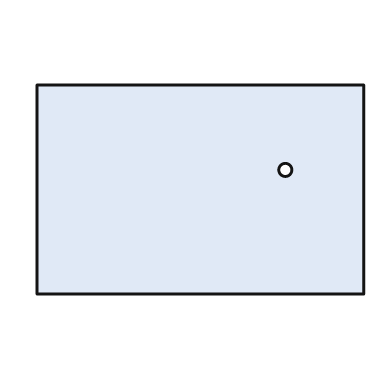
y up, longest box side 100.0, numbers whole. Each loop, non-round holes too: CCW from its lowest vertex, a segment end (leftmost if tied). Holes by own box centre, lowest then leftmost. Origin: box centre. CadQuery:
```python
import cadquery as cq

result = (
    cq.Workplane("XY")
    .moveTo(-50.0, -32.0)
    .lineTo(50.0, -32.0)
    .lineTo(50.0, 32.0)
    .lineTo(-50.0, 32.0)
    .close()
    .moveTo(26.0, 6.0)
    .circle(2.0)
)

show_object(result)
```